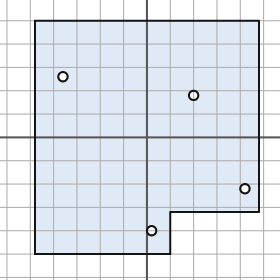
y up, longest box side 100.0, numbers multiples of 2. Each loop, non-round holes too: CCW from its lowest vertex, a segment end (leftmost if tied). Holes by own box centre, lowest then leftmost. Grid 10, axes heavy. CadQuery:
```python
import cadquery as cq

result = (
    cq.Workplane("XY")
    .moveTo(-48.0, -50.0)
    .lineTo(10.0, -50.0)
    .lineTo(10.0, -32.0)
    .lineTo(48.0, -32.0)
    .lineTo(48.0, 50.0)
    .lineTo(-48.0, 50.0)
    .close()
    .moveTo(2.0, -40.0)
    .circle(2.0)
    .moveTo(42.0, -22.0)
    .circle(2.0)
    .moveTo(20.0, 18.0)
    .circle(2.0)
    .moveTo(-36.0, 26.0)
    .circle(2.0)
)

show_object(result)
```